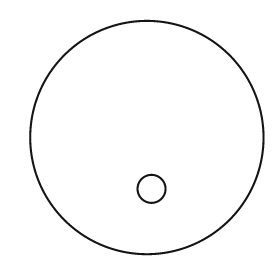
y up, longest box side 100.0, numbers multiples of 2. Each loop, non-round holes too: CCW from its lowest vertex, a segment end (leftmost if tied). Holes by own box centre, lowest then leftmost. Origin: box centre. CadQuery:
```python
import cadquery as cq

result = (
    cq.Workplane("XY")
    .moveTo(0.0, 0.0)
    .circle(50.0)
    .moveTo(2.0, -22.0)
    .circle(6.0)
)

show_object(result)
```